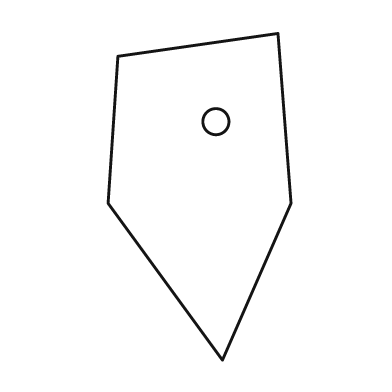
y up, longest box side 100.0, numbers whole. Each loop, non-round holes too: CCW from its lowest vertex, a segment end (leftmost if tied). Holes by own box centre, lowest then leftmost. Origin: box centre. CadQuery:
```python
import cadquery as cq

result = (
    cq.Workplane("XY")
    .moveTo(7.0, -50.0)
    .lineTo(28.0, -2.0)
    .lineTo(24.0, 50.0)
    .lineTo(-25.0, 43.0)
    .lineTo(-28.0, -2.0)
    .close()
    .moveTo(5.0, 23.0)
    .circle(4.0)
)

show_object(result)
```